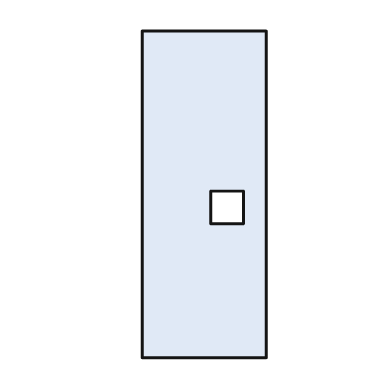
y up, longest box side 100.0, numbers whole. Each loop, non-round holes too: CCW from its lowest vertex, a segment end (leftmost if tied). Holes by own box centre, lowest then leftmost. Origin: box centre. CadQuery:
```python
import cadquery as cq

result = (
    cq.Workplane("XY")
    .moveTo(-19.0, -50.0)
    .lineTo(19.0, -50.0)
    .lineTo(19.0, 50.0)
    .lineTo(-19.0, 50.0)
    .close()
    .moveTo(2.0, -9.0)
    .lineTo(12.0, -9.0)
    .lineTo(12.0, 1.0)
    .lineTo(2.0, 1.0)
    .close()
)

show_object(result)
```